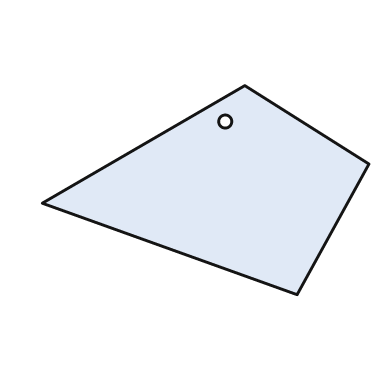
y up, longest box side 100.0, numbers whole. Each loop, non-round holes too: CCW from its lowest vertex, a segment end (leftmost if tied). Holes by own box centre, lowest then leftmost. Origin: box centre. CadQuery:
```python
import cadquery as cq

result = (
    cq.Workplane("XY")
    .moveTo(28.0, -32.0)
    .lineTo(50.0, 8.0)
    .lineTo(12.0, 32.0)
    .lineTo(-50.0, -4.0)
    .close()
    .moveTo(6.0, 21.0)
    .circle(2.0)
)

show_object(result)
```